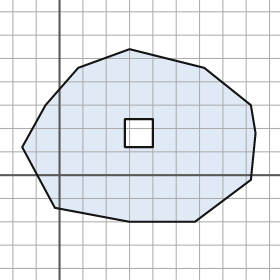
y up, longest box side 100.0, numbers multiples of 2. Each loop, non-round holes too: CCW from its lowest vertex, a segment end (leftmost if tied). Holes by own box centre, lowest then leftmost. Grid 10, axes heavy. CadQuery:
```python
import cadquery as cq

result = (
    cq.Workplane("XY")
    .moveTo(30.0, -20.0)
    .lineTo(58.0, -20.0)
    .lineTo(82.0, -2.0)
    .lineTo(84.0, 18.0)
    .lineTo(82.0, 30.0)
    .lineTo(62.0, 46.0)
    .lineTo(30.0, 54.0)
    .lineTo(8.0, 46.0)
    .lineTo(-6.0, 30.0)
    .lineTo(-16.0, 12.0)
    .lineTo(-2.0, -14.0)
    .close()
    .moveTo(28.0, 12.0)
    .lineTo(40.0, 12.0)
    .lineTo(40.0, 24.0)
    .lineTo(28.0, 24.0)
    .close()
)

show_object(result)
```